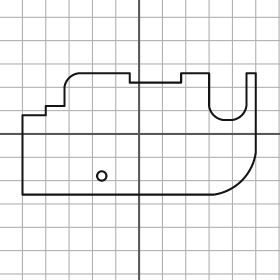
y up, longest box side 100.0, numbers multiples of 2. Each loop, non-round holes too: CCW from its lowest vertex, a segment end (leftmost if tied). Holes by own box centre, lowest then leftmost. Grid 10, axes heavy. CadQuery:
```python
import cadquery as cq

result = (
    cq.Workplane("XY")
    .moveTo(-50.0, -26.0)
    .lineTo(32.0, -26.0)
    .threePointArc((44.0, -20.0), (50.0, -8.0))
    .lineTo(50.0, 26.0)
    .lineTo(46.0, 26.0)
    .lineTo(46.0, 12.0)
    .threePointArc((44.0, 8.0), (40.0, 6.0))
    .lineTo(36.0, 6.0)
    .threePointArc((32.0, 8.0), (30.0, 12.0))
    .lineTo(30.0, 26.0)
    .lineTo(18.0, 26.0)
    .lineTo(18.0, 22.0)
    .lineTo(-4.0, 22.0)
    .lineTo(-4.0, 26.0)
    .lineTo(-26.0, 26.0)
    .threePointArc((-30.0, 24.0), (-32.0, 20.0))
    .lineTo(-32.0, 12.0)
    .lineTo(-40.0, 12.0)
    .lineTo(-40.0, 8.0)
    .lineTo(-50.0, 8.0)
    .close()
    .moveTo(-16.0, -18.0)
    .circle(2.0)
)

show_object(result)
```